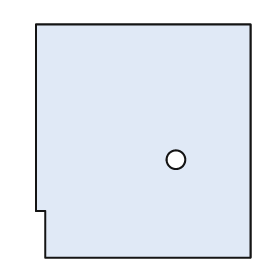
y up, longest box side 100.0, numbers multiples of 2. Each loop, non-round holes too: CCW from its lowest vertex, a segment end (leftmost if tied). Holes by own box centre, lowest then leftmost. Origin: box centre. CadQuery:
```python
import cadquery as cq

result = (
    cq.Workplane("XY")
    .moveTo(-42.0, -50.0)
    .lineTo(46.0, -50.0)
    .lineTo(46.0, 50.0)
    .lineTo(-46.0, 50.0)
    .lineTo(-46.0, -30.0)
    .lineTo(-42.0, -30.0)
    .close()
    .moveTo(14.0, -8.0)
    .circle(4.0)
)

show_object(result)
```